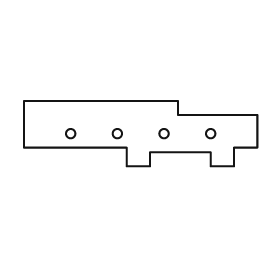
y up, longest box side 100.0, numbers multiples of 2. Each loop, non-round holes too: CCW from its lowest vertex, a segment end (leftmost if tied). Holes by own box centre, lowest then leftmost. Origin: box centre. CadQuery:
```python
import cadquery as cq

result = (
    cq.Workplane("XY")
    .moveTo(-6.0, -14.0)
    .lineTo(4.0, -14.0)
    .lineTo(4.0, -8.0)
    .lineTo(30.0, -8.0)
    .lineTo(30.0, -14.0)
    .lineTo(40.0, -14.0)
    .lineTo(40.0, -6.0)
    .lineTo(50.0, -6.0)
    .lineTo(50.0, 8.0)
    .lineTo(16.0, 8.0)
    .lineTo(16.0, 14.0)
    .lineTo(-50.0, 14.0)
    .lineTo(-50.0, -6.0)
    .lineTo(-6.0, -6.0)
    .close()
    .moveTo(-30.0, 0.0)
    .circle(2.0)
    .moveTo(-10.0, 0.0)
    .circle(2.0)
    .moveTo(10.0, 0.0)
    .circle(2.0)
    .moveTo(30.0, 0.0)
    .circle(2.0)
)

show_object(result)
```